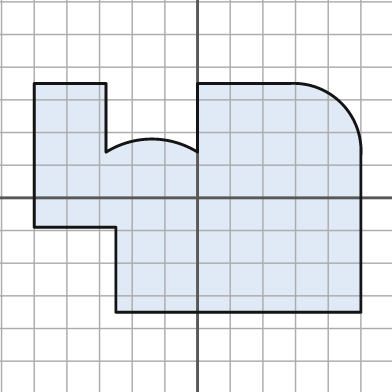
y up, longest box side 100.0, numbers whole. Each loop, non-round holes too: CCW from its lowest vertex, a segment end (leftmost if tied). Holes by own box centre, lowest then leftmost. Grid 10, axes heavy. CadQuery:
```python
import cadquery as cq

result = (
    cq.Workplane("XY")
    .moveTo(-25.0, -35.0)
    .lineTo(50.0, -35.0)
    .lineTo(50.0, 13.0)
    .threePointArc((44.0, 29.0), (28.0, 35.0))
    .lineTo(0.0, 35.0)
    .lineTo(0.0, 14.0)
    .threePointArc((-14.0, 18.0), (-28.0, 14.0))
    .lineTo(-28.0, 35.0)
    .lineTo(-50.0, 35.0)
    .lineTo(-50.0, -9.0)
    .lineTo(-25.0, -9.0)
    .close()
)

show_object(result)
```